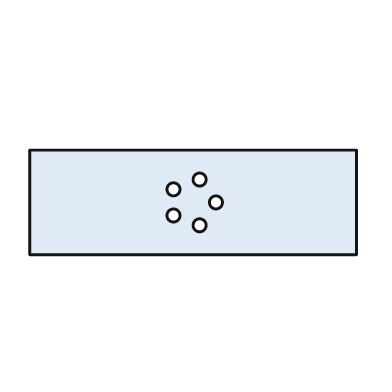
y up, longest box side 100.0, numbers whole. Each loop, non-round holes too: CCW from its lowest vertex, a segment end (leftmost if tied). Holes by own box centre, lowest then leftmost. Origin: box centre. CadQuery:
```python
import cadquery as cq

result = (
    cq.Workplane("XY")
    .moveTo(-50.0, -16.0)
    .lineTo(50.0, -16.0)
    .lineTo(50.0, 16.0)
    .lineTo(-50.0, 16.0)
    .close()
    .moveTo(2.0, -7.0)
    .circle(2.0)
    .moveTo(-6.0, -4.0)
    .circle(2.0)
    .moveTo(7.0, 0.0)
    .circle(2.0)
    .moveTo(-6.0, 4.0)
    .circle(2.0)
    .moveTo(2.0, 7.0)
    .circle(2.0)
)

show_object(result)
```